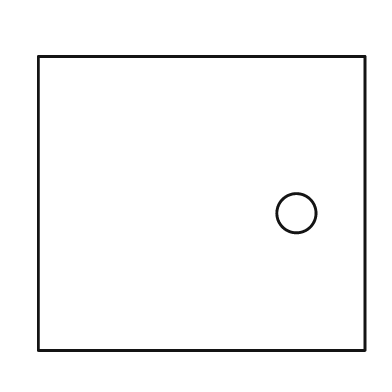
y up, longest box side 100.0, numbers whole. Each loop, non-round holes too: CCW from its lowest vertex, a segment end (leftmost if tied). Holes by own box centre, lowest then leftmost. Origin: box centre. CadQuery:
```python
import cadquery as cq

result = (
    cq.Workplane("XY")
    .moveTo(-50.0, -45.0)
    .lineTo(50.0, -45.0)
    .lineTo(50.0, 45.0)
    .lineTo(-50.0, 45.0)
    .close()
    .moveTo(29.0, -3.0)
    .circle(6.0)
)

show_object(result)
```